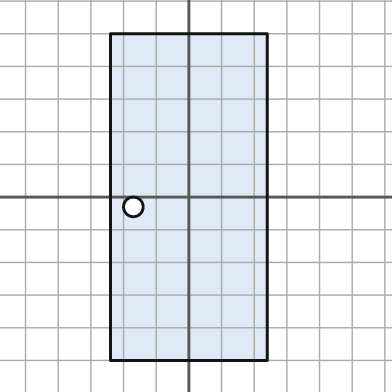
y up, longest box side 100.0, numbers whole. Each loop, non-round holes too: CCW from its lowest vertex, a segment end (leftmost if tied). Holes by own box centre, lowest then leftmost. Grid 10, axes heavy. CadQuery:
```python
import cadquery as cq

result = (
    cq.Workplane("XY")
    .moveTo(-24.0, -50.0)
    .lineTo(24.0, -50.0)
    .lineTo(24.0, 50.0)
    .lineTo(-24.0, 50.0)
    .close()
    .moveTo(-17.0, -3.0)
    .circle(3.0)
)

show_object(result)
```